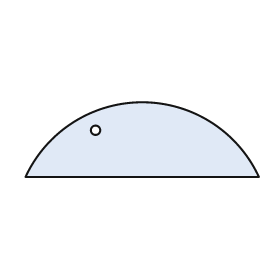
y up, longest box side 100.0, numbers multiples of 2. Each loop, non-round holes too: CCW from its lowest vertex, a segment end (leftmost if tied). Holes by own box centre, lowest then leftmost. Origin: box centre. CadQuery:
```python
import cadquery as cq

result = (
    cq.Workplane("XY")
    .moveTo(-50.0, -16.0)
    .lineTo(50.0, -16.0)
    .threePointArc((0.0, 16.0), (-50.0, -16.0))
    .close()
    .moveTo(-20.0, 4.0)
    .circle(2.0)
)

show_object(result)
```